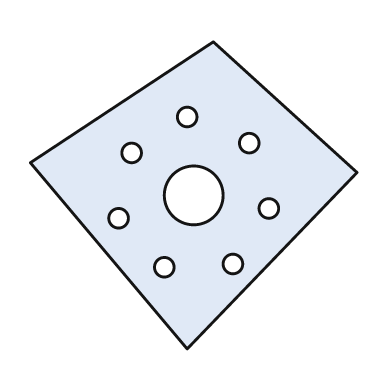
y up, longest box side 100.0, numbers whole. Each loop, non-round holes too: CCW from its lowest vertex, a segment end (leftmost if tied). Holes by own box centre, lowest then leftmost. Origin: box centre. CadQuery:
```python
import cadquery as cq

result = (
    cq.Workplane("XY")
    .moveTo(-2.0, -47.0)
    .lineTo(50.0, 7.0)
    .lineTo(6.0, 47.0)
    .lineTo(-50.0, 10.0)
    .close()
    .moveTo(-9.0, -22.0)
    .circle(3.0)
    .moveTo(12.0, -21.0)
    .circle(3.0)
    .moveTo(-23.0, -7.0)
    .circle(3.0)
    .moveTo(23.0, -4.0)
    .circle(3.0)
    .moveTo(0.0, 0.0)
    .circle(9.0)
    .moveTo(-19.0, 13.0)
    .circle(3.0)
    .moveTo(17.0, 16.0)
    .circle(3.0)
    .moveTo(-2.0, 24.0)
    .circle(3.0)
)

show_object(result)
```